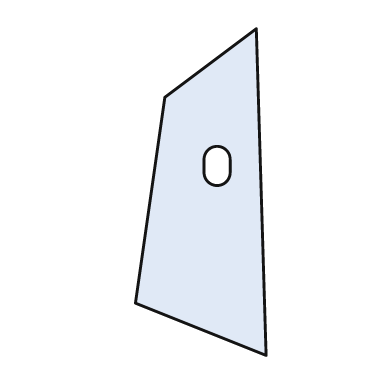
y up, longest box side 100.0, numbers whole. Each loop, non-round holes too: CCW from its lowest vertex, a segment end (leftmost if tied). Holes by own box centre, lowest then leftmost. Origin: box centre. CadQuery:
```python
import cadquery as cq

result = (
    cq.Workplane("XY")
    .moveTo(20.0, -50.0)
    .lineTo(17.0, 50.0)
    .lineTo(-11.0, 29.0)
    .lineTo(-20.0, -34.0)
    .close()
    .moveTo(1.0, 6.0)
    .threePointArc((5.0, 2.0), (9.0, 6.0))
    .lineTo(9.0, 10.0)
    .threePointArc((5.0, 14.0), (1.0, 10.0))
    .close()
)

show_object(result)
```